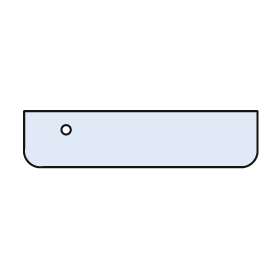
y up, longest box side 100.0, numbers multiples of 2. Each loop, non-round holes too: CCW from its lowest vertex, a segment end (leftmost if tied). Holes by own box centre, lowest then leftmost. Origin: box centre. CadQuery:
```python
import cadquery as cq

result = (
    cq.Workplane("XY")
    .moveTo(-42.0, -12.0)
    .lineTo(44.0, -12.0)
    .threePointArc((48.0, -10.0), (50.0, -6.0))
    .lineTo(50.0, 12.0)
    .lineTo(-50.0, 12.0)
    .lineTo(-50.0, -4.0)
    .threePointArc((-48.0, -10.0), (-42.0, -12.0))
    .close()
    .moveTo(-32.0, 4.0)
    .circle(2.0)
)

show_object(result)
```